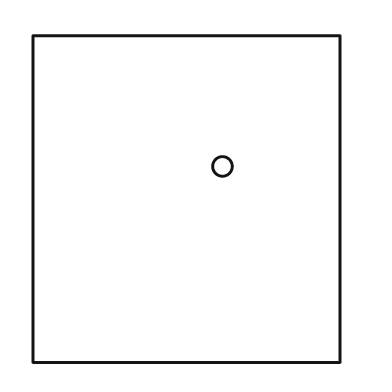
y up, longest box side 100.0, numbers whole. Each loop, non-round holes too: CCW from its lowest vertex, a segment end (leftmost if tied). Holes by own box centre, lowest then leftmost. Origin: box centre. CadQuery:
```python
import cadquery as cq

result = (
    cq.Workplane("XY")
    .moveTo(-47.0, -50.0)
    .lineTo(47.0, -50.0)
    .lineTo(47.0, 50.0)
    .lineTo(-47.0, 50.0)
    .close()
    .moveTo(11.0, 10.0)
    .circle(3.0)
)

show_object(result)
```